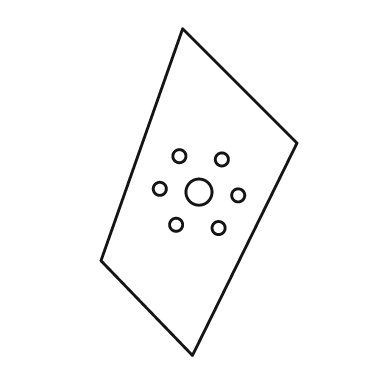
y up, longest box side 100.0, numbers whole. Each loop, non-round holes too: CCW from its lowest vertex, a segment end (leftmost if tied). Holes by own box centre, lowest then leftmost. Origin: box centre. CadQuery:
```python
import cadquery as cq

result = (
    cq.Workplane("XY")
    .moveTo(-2.0, -50.0)
    .lineTo(30.0, 15.0)
    .lineTo(-5.0, 50.0)
    .lineTo(-30.0, -21.0)
    .close()
    .moveTo(6.0, -11.0)
    .circle(2.0)
    .moveTo(-7.0, -10.0)
    .circle(2.0)
    .moveTo(12.0, -1.0)
    .circle(2.0)
    .moveTo(0.0, 0.0)
    .circle(4.0)
    .moveTo(-12.0, 1.0)
    .circle(2.0)
    .moveTo(7.0, 10.0)
    .circle(2.0)
    .moveTo(-6.0, 11.0)
    .circle(2.0)
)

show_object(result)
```